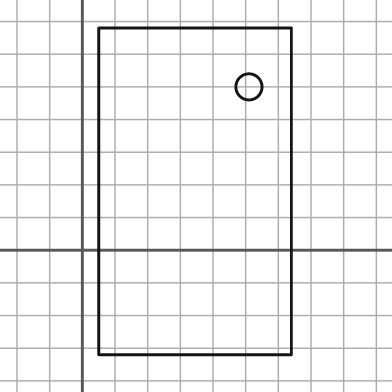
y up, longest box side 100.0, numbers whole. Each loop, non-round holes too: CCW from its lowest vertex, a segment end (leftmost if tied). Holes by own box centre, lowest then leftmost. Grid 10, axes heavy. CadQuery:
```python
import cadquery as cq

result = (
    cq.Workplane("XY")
    .moveTo(5.0, -32.0)
    .lineTo(64.0, -32.0)
    .lineTo(64.0, 68.0)
    .lineTo(5.0, 68.0)
    .close()
    .moveTo(51.0, 50.0)
    .circle(4.0)
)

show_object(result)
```